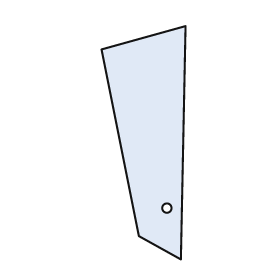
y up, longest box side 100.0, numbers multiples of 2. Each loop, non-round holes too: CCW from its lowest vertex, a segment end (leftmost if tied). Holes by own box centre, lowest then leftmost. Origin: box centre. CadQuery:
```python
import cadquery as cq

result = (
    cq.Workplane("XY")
    .moveTo(16.0, -50.0)
    .lineTo(18.0, 50.0)
    .lineTo(-18.0, 40.0)
    .lineTo(-2.0, -40.0)
    .close()
    .moveTo(10.0, -28.0)
    .circle(2.0)
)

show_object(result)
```